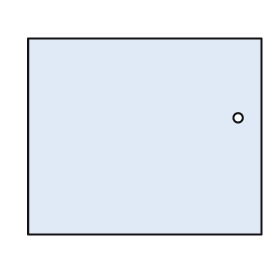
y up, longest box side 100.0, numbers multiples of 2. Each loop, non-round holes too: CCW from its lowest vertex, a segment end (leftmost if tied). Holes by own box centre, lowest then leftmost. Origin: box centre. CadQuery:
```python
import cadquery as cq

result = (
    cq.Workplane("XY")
    .moveTo(-50.0, -42.0)
    .lineTo(50.0, -42.0)
    .lineTo(50.0, 42.0)
    .lineTo(-50.0, 42.0)
    .close()
    .moveTo(40.0, 8.0)
    .circle(2.0)
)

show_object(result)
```